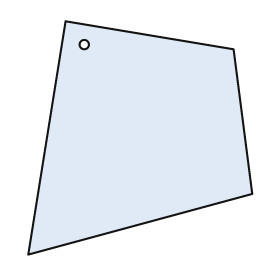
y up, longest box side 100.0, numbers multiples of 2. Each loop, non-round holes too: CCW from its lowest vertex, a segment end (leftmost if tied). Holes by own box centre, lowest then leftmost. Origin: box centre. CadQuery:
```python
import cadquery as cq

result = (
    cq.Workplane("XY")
    .moveTo(-48.0, -50.0)
    .lineTo(48.0, -24.0)
    .lineTo(40.0, 38.0)
    .lineTo(-32.0, 50.0)
    .close()
    .moveTo(-24.0, 40.0)
    .circle(2.0)
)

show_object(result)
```